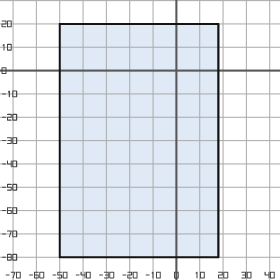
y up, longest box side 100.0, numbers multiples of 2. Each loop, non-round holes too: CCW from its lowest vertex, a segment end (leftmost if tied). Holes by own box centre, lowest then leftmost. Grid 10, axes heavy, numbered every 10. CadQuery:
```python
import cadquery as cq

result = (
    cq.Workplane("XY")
    .moveTo(-50.0, -80.0)
    .lineTo(18.0, -80.0)
    .lineTo(18.0, 20.0)
    .lineTo(-50.0, 20.0)
    .close()
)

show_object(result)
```